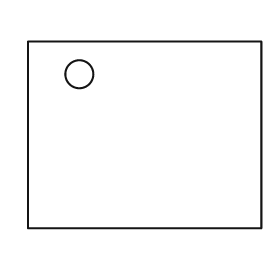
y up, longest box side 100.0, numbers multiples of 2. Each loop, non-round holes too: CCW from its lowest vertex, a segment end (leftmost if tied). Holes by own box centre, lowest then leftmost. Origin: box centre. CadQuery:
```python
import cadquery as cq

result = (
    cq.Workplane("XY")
    .moveTo(-50.0, -40.0)
    .lineTo(50.0, -40.0)
    .lineTo(50.0, 40.0)
    .lineTo(-50.0, 40.0)
    .close()
    .moveTo(-28.0, 26.0)
    .circle(6.0)
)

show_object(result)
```